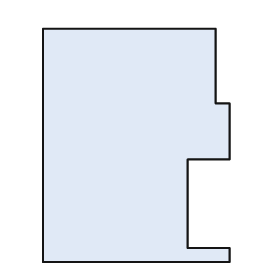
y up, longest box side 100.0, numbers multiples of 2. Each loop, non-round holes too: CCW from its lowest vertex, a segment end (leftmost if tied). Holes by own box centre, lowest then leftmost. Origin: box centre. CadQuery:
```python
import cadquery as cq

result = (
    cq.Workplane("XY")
    .moveTo(-40.0, -50.0)
    .lineTo(40.0, -50.0)
    .lineTo(40.0, -44.0)
    .lineTo(22.0, -44.0)
    .lineTo(22.0, -6.0)
    .lineTo(40.0, -6.0)
    .lineTo(40.0, 18.0)
    .lineTo(34.0, 18.0)
    .lineTo(34.0, 50.0)
    .lineTo(-40.0, 50.0)
    .close()
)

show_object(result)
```